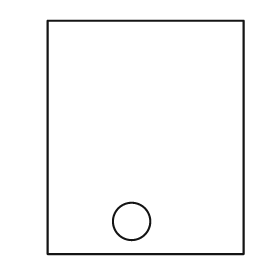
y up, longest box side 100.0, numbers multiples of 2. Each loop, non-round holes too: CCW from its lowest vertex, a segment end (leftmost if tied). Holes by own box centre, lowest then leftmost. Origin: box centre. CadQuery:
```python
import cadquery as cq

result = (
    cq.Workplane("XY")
    .moveTo(-42.0, -50.0)
    .lineTo(42.0, -50.0)
    .lineTo(42.0, 50.0)
    .lineTo(-42.0, 50.0)
    .close()
    .moveTo(-6.0, -36.0)
    .circle(8.0)
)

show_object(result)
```